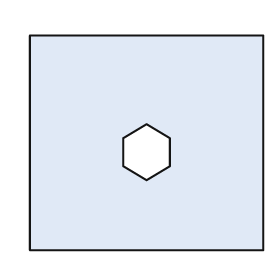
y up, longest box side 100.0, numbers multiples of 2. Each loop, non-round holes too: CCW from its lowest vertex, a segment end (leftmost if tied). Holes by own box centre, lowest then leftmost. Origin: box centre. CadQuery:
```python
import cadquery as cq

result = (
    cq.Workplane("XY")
    .moveTo(-50.0, -46.0)
    .lineTo(50.0, -46.0)
    .lineTo(50.0, 46.0)
    .lineTo(-50.0, 46.0)
    .close()
    .moveTo(0.0, -16.0)
    .lineTo(10.0, -10.0)
    .lineTo(10.0, 2.0)
    .lineTo(0.0, 8.0)
    .lineTo(-10.0, 2.0)
    .lineTo(-10.0, -10.0)
    .close()
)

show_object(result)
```